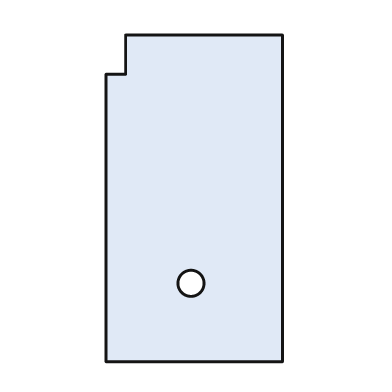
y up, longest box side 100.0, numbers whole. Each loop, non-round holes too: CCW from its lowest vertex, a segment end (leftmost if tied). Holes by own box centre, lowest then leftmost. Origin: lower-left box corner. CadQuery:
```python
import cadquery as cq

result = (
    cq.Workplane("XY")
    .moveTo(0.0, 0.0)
    .lineTo(54.0, 0.0)
    .lineTo(54.0, 100.0)
    .lineTo(6.0, 100.0)
    .lineTo(6.0, 88.0)
    .lineTo(0.0, 88.0)
    .close()
    .moveTo(26.0, 24.0)
    .circle(4.0)
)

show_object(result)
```